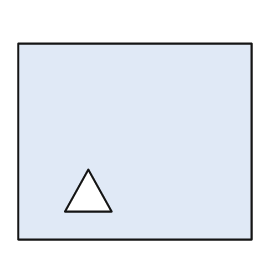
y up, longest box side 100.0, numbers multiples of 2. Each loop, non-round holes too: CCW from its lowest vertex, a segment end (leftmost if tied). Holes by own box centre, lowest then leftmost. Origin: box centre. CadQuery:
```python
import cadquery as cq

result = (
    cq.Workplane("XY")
    .moveTo(-50.0, -42.0)
    .lineTo(50.0, -42.0)
    .lineTo(50.0, 42.0)
    .lineTo(-50.0, 42.0)
    .close()
    .moveTo(-30.0, -30.0)
    .lineTo(-10.0, -30.0)
    .lineTo(-20.0, -12.0)
    .close()
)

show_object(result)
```